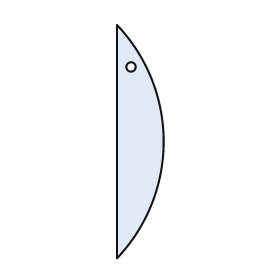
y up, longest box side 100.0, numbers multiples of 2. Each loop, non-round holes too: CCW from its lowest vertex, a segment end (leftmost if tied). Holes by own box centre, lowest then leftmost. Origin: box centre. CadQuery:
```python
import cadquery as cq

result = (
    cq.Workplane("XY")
    .moveTo(-10.0, -50.0)
    .threePointArc((10.0, 0.0), (-10.0, 50.0))
    .close()
    .moveTo(-4.0, 32.0)
    .circle(2.0)
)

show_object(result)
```